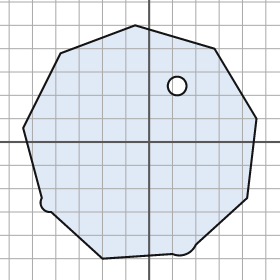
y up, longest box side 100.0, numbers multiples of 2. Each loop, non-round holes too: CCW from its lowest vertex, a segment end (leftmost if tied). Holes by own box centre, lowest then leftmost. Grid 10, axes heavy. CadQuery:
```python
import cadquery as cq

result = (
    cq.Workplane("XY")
    .moveTo(-20.0, -50.0)
    .lineTo(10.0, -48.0)
    .threePointArc((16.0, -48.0), (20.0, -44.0))
    .lineTo(42.0, -24.0)
    .lineTo(46.0, 10.0)
    .lineTo(28.0, 40.0)
    .lineTo(-6.0, 50.0)
    .lineTo(-38.0, 38.0)
    .lineTo(-54.0, 6.0)
    .lineTo(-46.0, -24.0)
    .threePointArc((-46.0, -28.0), (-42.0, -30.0))
    .close()
    .moveTo(12.0, 24.0)
    .circle(4.0)
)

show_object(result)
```